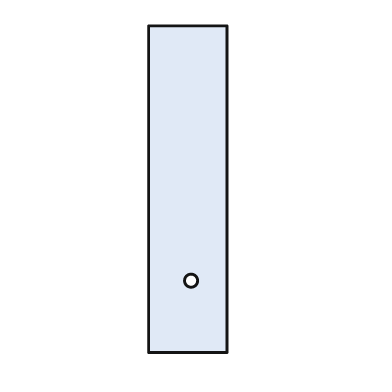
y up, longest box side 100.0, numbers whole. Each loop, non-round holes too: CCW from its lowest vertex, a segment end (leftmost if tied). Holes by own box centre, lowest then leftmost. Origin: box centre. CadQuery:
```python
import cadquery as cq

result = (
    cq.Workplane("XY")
    .moveTo(-12.0, -50.0)
    .lineTo(12.0, -50.0)
    .lineTo(12.0, 50.0)
    .lineTo(-12.0, 50.0)
    .close()
    .moveTo(1.0, -28.0)
    .circle(2.0)
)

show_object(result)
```